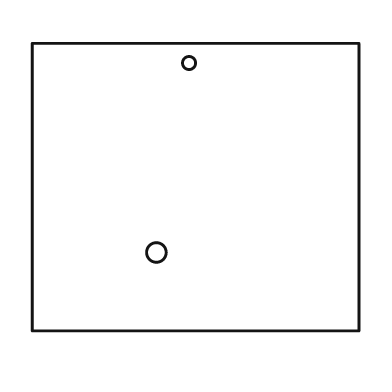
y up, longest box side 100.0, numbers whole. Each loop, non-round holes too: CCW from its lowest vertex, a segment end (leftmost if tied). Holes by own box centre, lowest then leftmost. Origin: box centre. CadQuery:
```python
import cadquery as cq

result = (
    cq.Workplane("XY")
    .moveTo(-50.0, -44.0)
    .lineTo(50.0, -44.0)
    .lineTo(50.0, 44.0)
    .lineTo(-50.0, 44.0)
    .close()
    .moveTo(-12.0, -20.0)
    .circle(3.0)
    .moveTo(-2.0, 38.0)
    .circle(2.0)
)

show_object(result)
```